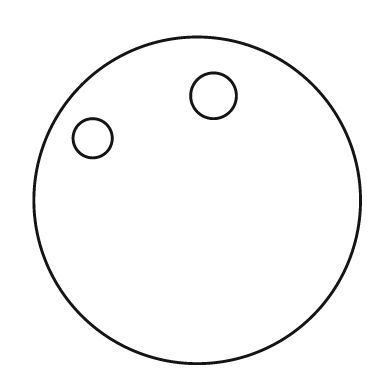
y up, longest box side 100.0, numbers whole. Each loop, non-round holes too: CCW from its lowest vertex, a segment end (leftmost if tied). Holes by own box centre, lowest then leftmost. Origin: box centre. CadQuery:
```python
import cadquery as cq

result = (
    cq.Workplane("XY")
    .moveTo(0.0, 0.0)
    .circle(50.0)
    .moveTo(-32.0, 19.0)
    .circle(6.0)
    .moveTo(5.0, 32.0)
    .circle(7.0)
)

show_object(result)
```